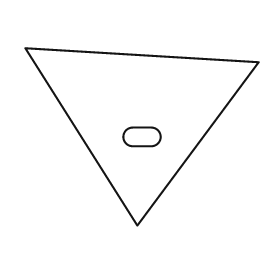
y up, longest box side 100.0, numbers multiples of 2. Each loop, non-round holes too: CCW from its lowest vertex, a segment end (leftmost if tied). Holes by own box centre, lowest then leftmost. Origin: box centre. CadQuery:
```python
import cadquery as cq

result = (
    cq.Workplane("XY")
    .moveTo(-2.0, -38.0)
    .lineTo(50.0, 32.0)
    .lineTo(-50.0, 38.0)
    .close()
    .moveTo(-4.0, -4.0)
    .lineTo(4.0, -4.0)
    .threePointArc((8.0, 0.0), (4.0, 4.0))
    .lineTo(-4.0, 4.0)
    .threePointArc((-8.0, 0.0), (-4.0, -4.0))
    .close()
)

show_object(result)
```